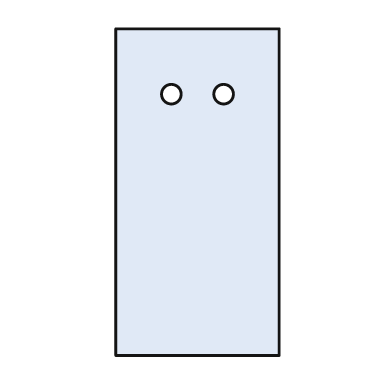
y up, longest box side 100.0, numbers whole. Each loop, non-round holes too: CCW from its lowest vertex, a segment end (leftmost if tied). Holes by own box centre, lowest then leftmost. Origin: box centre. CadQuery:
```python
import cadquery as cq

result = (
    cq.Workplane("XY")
    .moveTo(-25.0, -50.0)
    .lineTo(25.0, -50.0)
    .lineTo(25.0, 50.0)
    .lineTo(-25.0, 50.0)
    .close()
    .moveTo(-8.0, 30.0)
    .circle(3.0)
    .moveTo(8.0, 30.0)
    .circle(3.0)
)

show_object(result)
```